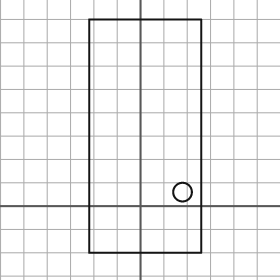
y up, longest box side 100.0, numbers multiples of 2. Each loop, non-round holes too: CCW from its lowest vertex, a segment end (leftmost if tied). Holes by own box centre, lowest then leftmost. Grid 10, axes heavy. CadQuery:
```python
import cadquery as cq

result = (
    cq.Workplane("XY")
    .moveTo(-22.0, -20.0)
    .lineTo(26.0, -20.0)
    .lineTo(26.0, 80.0)
    .lineTo(-22.0, 80.0)
    .close()
    .moveTo(18.0, 6.0)
    .circle(4.0)
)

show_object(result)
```